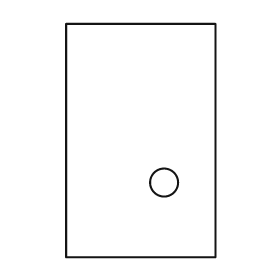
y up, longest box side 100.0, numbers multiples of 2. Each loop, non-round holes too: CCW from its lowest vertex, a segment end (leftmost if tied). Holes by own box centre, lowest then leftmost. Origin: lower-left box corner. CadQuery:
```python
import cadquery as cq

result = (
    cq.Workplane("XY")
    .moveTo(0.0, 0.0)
    .lineTo(64.0, 0.0)
    .lineTo(64.0, 100.0)
    .lineTo(0.0, 100.0)
    .close()
    .moveTo(42.0, 32.0)
    .circle(6.0)
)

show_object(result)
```